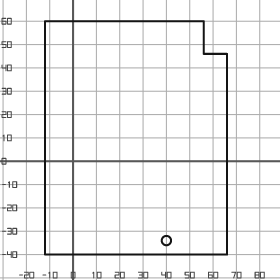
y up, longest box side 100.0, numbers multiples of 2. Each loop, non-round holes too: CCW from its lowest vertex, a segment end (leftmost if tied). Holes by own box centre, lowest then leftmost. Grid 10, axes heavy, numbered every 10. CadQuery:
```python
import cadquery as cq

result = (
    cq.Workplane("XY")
    .moveTo(-12.0, -40.0)
    .lineTo(66.0, -40.0)
    .lineTo(66.0, 46.0)
    .lineTo(56.0, 46.0)
    .lineTo(56.0, 60.0)
    .lineTo(-12.0, 60.0)
    .close()
    .moveTo(40.0, -34.0)
    .circle(2.0)
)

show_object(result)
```